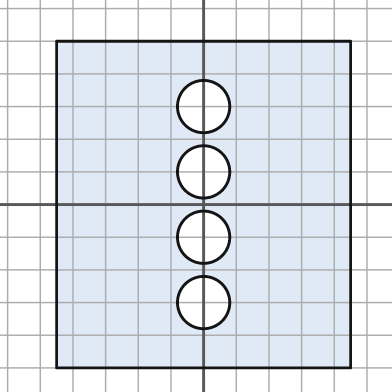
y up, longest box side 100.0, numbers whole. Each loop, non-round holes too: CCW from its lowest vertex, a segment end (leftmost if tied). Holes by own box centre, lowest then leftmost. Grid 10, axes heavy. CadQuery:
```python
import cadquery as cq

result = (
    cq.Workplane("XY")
    .moveTo(-45.0, -50.0)
    .lineTo(45.0, -50.0)
    .lineTo(45.0, 50.0)
    .lineTo(-45.0, 50.0)
    .close()
    .moveTo(0.0, -30.0)
    .circle(8.0)
    .moveTo(0.0, -10.0)
    .circle(8.0)
    .moveTo(0.0, 10.0)
    .circle(8.0)
    .moveTo(0.0, 30.0)
    .circle(8.0)
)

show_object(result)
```